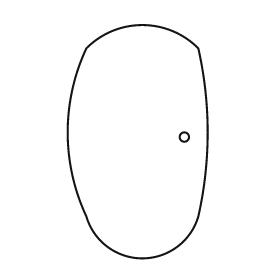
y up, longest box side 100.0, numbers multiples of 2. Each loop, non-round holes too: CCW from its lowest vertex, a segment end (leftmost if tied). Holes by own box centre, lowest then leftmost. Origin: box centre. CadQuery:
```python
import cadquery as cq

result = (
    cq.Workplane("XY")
    .moveTo(-22.0, -32.0)
    .threePointArc((2.0, -50.0), (26.0, -32.0))
    .threePointArc((30.0, 4.0), (26.0, 40.0))
    .threePointArc((2.0, 50.0), (-22.0, 40.0))
    .threePointArc((-30.0, 4.0), (-22.0, -32.0))
    .close()
    .moveTo(20.0, 2.0)
    .circle(2.0)
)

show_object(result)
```